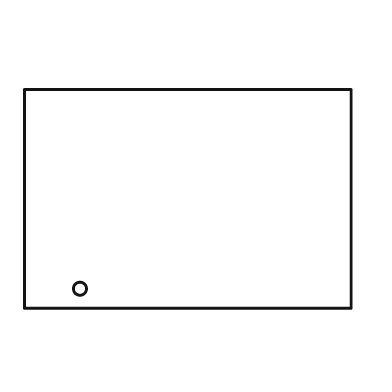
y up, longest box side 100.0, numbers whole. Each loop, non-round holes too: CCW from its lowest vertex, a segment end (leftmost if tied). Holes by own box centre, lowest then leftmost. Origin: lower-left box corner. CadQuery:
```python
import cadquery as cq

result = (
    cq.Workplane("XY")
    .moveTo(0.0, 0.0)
    .lineTo(100.0, 0.0)
    .lineTo(100.0, 67.0)
    .lineTo(0.0, 67.0)
    .close()
    .moveTo(17.0, 6.0)
    .circle(2.0)
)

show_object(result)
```